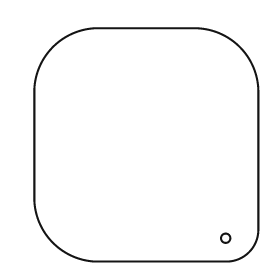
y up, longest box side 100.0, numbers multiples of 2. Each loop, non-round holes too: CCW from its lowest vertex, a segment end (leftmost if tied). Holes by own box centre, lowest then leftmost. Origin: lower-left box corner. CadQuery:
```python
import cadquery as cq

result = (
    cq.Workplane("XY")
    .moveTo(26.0, 0.0)
    .lineTo(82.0, 0.0)
    .threePointArc((92.0, 4.0), (96.0, 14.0))
    .lineTo(96.0, 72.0)
    .threePointArc((88.0, 92.0), (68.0, 100.0))
    .lineTo(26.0, 100.0)
    .threePointArc((8.0, 92.0), (0.0, 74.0))
    .lineTo(0.0, 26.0)
    .threePointArc((8.0, 8.0), (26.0, 0.0))
    .close()
    .moveTo(82.0, 10.0)
    .circle(2.0)
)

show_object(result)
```